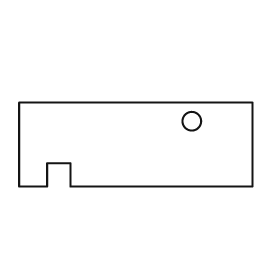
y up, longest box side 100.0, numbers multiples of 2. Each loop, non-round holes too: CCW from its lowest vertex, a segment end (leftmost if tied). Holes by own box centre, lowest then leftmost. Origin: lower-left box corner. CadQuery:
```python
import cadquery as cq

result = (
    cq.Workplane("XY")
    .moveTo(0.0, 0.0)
    .lineTo(12.0, 0.0)
    .lineTo(12.0, 10.0)
    .lineTo(22.0, 10.0)
    .lineTo(22.0, 0.0)
    .lineTo(100.0, 0.0)
    .lineTo(100.0, 36.0)
    .lineTo(0.0, 36.0)
    .close()
    .moveTo(74.0, 28.0)
    .circle(4.0)
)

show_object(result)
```